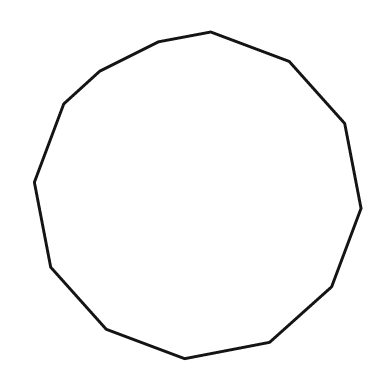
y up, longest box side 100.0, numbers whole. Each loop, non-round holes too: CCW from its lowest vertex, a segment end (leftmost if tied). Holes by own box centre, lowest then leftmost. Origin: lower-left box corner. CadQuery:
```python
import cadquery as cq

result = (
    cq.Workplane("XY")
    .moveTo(46.0, 0.0)
    .lineTo(72.0, 5.0)
    .lineTo(91.0, 22.0)
    .lineTo(100.0, 46.0)
    .lineTo(95.0, 72.0)
    .lineTo(78.0, 91.0)
    .lineTo(54.0, 100.0)
    .lineTo(38.0, 97.0)
    .lineTo(20.0, 88.0)
    .lineTo(9.0, 78.0)
    .lineTo(0.0, 54.0)
    .lineTo(5.0, 28.0)
    .lineTo(22.0, 9.0)
    .close()
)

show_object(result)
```